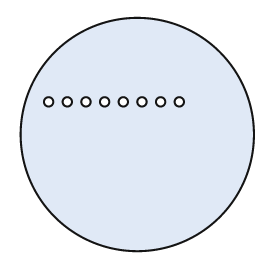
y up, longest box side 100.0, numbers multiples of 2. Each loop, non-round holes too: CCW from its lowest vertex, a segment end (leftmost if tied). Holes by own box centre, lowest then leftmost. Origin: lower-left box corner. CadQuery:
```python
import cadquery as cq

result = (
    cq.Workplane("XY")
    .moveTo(50.0, 50.0)
    .circle(50.0)
    .moveTo(12.0, 64.0)
    .circle(2.0)
    .moveTo(20.0, 64.0)
    .circle(2.0)
    .moveTo(28.0, 64.0)
    .circle(2.0)
    .moveTo(36.0, 64.0)
    .circle(2.0)
    .moveTo(44.0, 64.0)
    .circle(2.0)
    .moveTo(52.0, 64.0)
    .circle(2.0)
    .moveTo(60.0, 64.0)
    .circle(2.0)
    .moveTo(68.0, 64.0)
    .circle(2.0)
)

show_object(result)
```